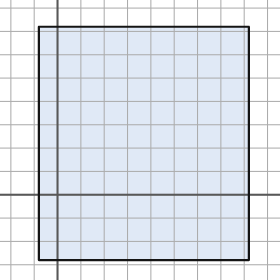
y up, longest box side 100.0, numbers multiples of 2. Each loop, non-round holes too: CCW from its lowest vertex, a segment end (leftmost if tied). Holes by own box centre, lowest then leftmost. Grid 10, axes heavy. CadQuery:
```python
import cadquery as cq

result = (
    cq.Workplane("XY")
    .moveTo(-8.0, -28.0)
    .lineTo(82.0, -28.0)
    .lineTo(82.0, 72.0)
    .lineTo(-8.0, 72.0)
    .close()
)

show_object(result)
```